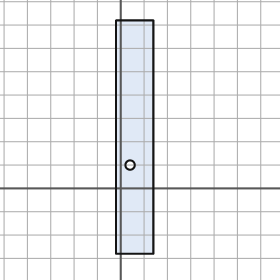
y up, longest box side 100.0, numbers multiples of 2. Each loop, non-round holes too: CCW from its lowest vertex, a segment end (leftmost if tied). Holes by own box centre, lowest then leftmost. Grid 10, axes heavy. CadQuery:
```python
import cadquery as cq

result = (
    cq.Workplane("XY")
    .moveTo(-2.0, -28.0)
    .lineTo(14.0, -28.0)
    .lineTo(14.0, 72.0)
    .lineTo(-2.0, 72.0)
    .close()
    .moveTo(4.0, 10.0)
    .circle(2.0)
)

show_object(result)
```